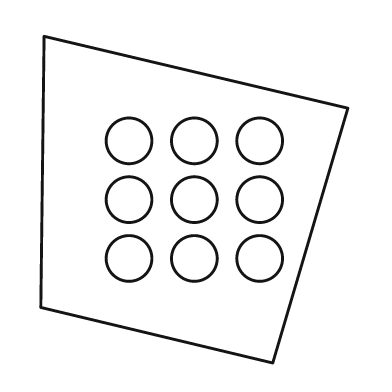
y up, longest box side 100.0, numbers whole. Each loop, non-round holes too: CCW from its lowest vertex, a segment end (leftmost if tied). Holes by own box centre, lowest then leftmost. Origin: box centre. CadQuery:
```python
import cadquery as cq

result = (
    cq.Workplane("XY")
    .moveTo(24.0, -50.0)
    .lineTo(47.0, 28.0)
    .lineTo(-46.0, 50.0)
    .lineTo(-47.0, -33.0)
    .close()
    .moveTo(-20.0, -18.0)
    .circle(7.0)
    .moveTo(0.0, -18.0)
    .circle(7.0)
    .moveTo(20.0, -18.0)
    .circle(7.0)
    .moveTo(-20.0, 0.0)
    .circle(7.0)
    .moveTo(0.0, 0.0)
    .circle(7.0)
    .moveTo(20.0, 0.0)
    .circle(7.0)
    .moveTo(-20.0, 18.0)
    .circle(7.0)
    .moveTo(0.0, 18.0)
    .circle(7.0)
    .moveTo(20.0, 18.0)
    .circle(7.0)
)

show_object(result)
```